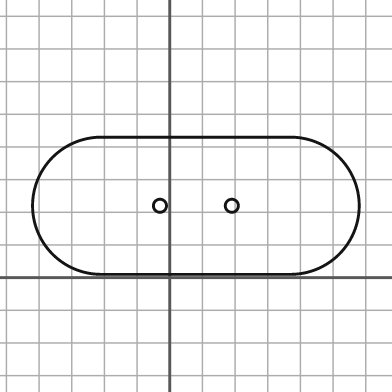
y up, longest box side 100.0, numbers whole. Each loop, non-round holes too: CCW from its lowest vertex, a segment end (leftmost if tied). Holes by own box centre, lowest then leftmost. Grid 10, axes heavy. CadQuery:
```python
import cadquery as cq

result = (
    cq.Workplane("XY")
    .moveTo(-21.0, 1.0)
    .lineTo(37.0, 1.0)
    .threePointArc((58.0, 22.0), (37.0, 43.0))
    .lineTo(-21.0, 43.0)
    .threePointArc((-42.0, 22.0), (-21.0, 1.0))
    .close()
    .moveTo(-3.0, 22.0)
    .circle(2.0)
    .moveTo(19.0, 22.0)
    .circle(2.0)
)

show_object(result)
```